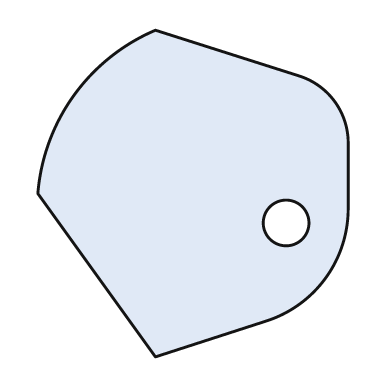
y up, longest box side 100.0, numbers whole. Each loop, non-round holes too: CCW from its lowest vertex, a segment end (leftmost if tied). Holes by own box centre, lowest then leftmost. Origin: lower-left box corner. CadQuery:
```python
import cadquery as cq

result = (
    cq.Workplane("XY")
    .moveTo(36.0, 0.0)
    .lineTo(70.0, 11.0)
    .threePointArc((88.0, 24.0), (95.0, 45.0))
    .lineTo(95.0, 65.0)
    .threePointArc((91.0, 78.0), (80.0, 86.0))
    .lineTo(36.0, 100.0)
    .threePointArc((11.0, 80.0), (0.0, 50.0))
    .close()
    .moveTo(76.0, 41.0)
    .circle(7.0)
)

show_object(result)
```